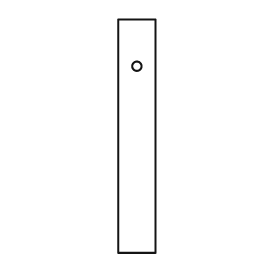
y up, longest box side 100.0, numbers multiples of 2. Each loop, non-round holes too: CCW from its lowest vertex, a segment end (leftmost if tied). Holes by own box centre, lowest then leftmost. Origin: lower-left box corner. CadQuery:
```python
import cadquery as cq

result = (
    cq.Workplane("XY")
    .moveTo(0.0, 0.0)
    .lineTo(16.0, 0.0)
    .lineTo(16.0, 100.0)
    .lineTo(0.0, 100.0)
    .close()
    .moveTo(8.0, 80.0)
    .circle(2.0)
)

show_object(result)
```